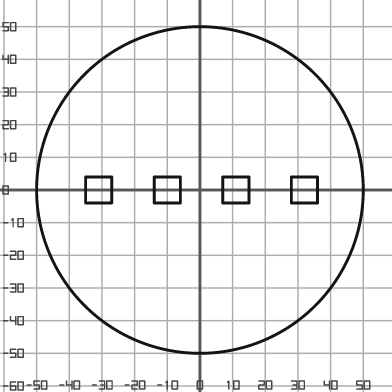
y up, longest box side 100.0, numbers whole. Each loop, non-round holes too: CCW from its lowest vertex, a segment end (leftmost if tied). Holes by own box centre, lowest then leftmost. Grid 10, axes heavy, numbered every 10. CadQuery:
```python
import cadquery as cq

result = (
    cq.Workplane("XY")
    .moveTo(0.0, 0.0)
    .circle(50.0)
    .moveTo(-35.0, -4.0)
    .lineTo(-27.0, -4.0)
    .lineTo(-27.0, 4.0)
    .lineTo(-35.0, 4.0)
    .close()
    .moveTo(-14.0, -4.0)
    .lineTo(-6.0, -4.0)
    .lineTo(-6.0, 4.0)
    .lineTo(-14.0, 4.0)
    .close()
    .moveTo(7.0, -4.0)
    .lineTo(15.0, -4.0)
    .lineTo(15.0, 4.0)
    .lineTo(7.0, 4.0)
    .close()
    .moveTo(28.0, -4.0)
    .lineTo(36.0, -4.0)
    .lineTo(36.0, 4.0)
    .lineTo(28.0, 4.0)
    .close()
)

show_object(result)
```